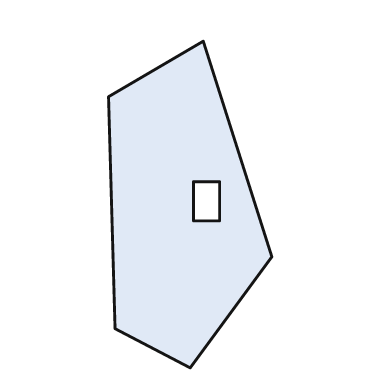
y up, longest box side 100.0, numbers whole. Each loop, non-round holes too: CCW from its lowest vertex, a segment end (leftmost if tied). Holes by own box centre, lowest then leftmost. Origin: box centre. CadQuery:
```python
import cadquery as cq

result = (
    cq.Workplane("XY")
    .moveTo(0.0, -50.0)
    .lineTo(25.0, -16.0)
    .lineTo(4.0, 50.0)
    .lineTo(-25.0, 33.0)
    .lineTo(-23.0, -38.0)
    .close()
    .moveTo(1.0, -5.0)
    .lineTo(9.0, -5.0)
    .lineTo(9.0, 7.0)
    .lineTo(1.0, 7.0)
    .close()
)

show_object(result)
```